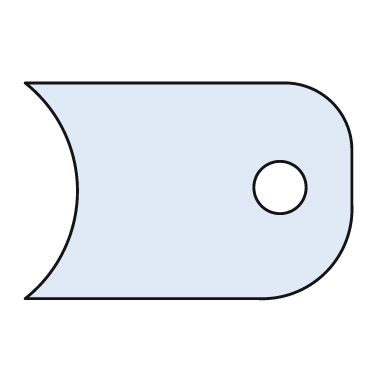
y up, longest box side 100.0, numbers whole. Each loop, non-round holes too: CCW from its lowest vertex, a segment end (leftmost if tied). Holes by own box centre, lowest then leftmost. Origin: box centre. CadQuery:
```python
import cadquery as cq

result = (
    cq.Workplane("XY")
    .moveTo(-50.0, -33.0)
    .lineTo(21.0, -33.0)
    .threePointArc((42.0, -25.0), (50.0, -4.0))
    .lineTo(50.0, 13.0)
    .threePointArc((44.0, 27.0), (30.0, 33.0))
    .lineTo(-50.0, 33.0)
    .threePointArc((-34.0, 0.0), (-50.0, -33.0))
    .close()
    .moveTo(28.0, 1.0)
    .circle(8.0)
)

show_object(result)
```